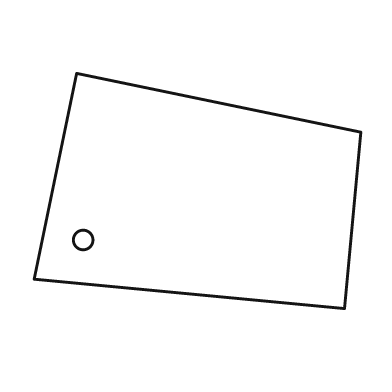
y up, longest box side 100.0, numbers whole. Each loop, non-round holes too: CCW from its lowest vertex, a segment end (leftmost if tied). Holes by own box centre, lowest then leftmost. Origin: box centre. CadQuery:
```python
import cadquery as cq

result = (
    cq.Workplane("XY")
    .moveTo(45.0, -36.0)
    .lineTo(50.0, 18.0)
    .lineTo(-37.0, 36.0)
    .lineTo(-50.0, -27.0)
    .close()
    .moveTo(-35.0, -15.0)
    .circle(3.0)
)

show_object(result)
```